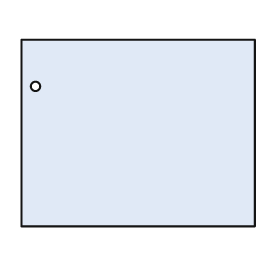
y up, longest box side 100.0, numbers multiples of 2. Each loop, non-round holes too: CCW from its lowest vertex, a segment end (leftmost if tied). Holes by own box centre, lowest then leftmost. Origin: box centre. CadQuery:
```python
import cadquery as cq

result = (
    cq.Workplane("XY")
    .moveTo(-50.0, -40.0)
    .lineTo(50.0, -40.0)
    .lineTo(50.0, 40.0)
    .lineTo(-50.0, 40.0)
    .close()
    .moveTo(-44.0, 20.0)
    .circle(2.0)
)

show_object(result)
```